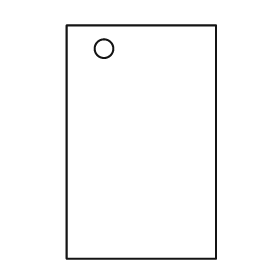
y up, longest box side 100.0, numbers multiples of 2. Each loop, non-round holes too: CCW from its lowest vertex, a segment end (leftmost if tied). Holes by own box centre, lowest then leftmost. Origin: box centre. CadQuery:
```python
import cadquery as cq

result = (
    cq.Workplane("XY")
    .moveTo(-32.0, -50.0)
    .lineTo(32.0, -50.0)
    .lineTo(32.0, 50.0)
    .lineTo(-32.0, 50.0)
    .close()
    .moveTo(-16.0, 40.0)
    .circle(4.0)
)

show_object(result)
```